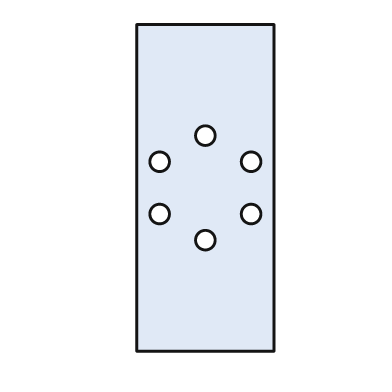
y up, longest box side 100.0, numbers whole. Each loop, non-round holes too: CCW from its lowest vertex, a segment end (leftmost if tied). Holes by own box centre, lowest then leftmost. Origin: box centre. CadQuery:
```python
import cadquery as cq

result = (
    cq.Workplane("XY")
    .moveTo(-21.0, -50.0)
    .lineTo(21.0, -50.0)
    .lineTo(21.0, 50.0)
    .lineTo(-21.0, 50.0)
    .close()
    .moveTo(0.0, -16.0)
    .circle(3.0)
    .moveTo(-14.0, -8.0)
    .circle(3.0)
    .moveTo(14.0, -8.0)
    .circle(3.0)
    .moveTo(-14.0, 8.0)
    .circle(3.0)
    .moveTo(14.0, 8.0)
    .circle(3.0)
    .moveTo(0.0, 16.0)
    .circle(3.0)
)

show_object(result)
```